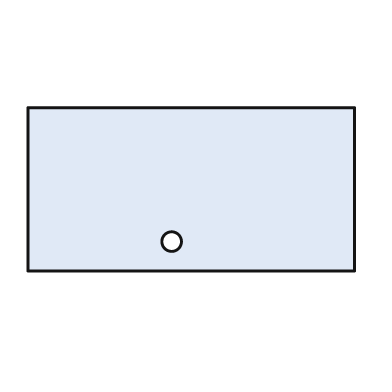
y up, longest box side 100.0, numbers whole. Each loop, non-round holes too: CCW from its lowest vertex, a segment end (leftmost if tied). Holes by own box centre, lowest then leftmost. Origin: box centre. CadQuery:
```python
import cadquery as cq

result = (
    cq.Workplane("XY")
    .moveTo(-50.0, -25.0)
    .lineTo(50.0, -25.0)
    .lineTo(50.0, 25.0)
    .lineTo(-50.0, 25.0)
    .close()
    .moveTo(-6.0, -16.0)
    .circle(3.0)
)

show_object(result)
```